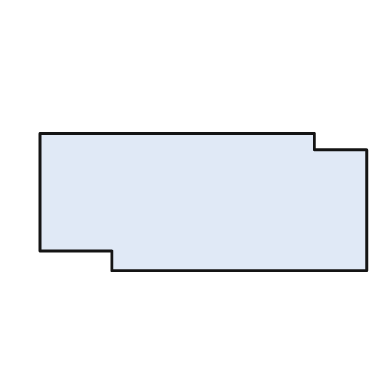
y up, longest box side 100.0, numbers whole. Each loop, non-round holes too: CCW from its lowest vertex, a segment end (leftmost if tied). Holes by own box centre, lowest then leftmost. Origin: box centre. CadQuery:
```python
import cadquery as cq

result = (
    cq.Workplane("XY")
    .moveTo(-28.0, -21.0)
    .lineTo(50.0, -21.0)
    .lineTo(50.0, 16.0)
    .lineTo(34.0, 16.0)
    .lineTo(34.0, 21.0)
    .lineTo(-50.0, 21.0)
    .lineTo(-50.0, -15.0)
    .lineTo(-28.0, -15.0)
    .close()
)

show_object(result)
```